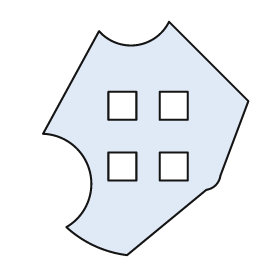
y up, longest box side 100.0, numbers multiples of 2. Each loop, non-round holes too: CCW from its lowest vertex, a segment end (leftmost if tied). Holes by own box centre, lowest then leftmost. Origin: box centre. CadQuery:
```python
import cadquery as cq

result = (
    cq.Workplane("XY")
    .moveTo(-8.0, -50.0)
    .lineTo(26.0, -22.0)
    .threePointArc((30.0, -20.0), (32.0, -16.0))
    .lineTo(44.0, 16.0)
    .lineTo(10.0, 50.0)
    .threePointArc((-4.0, 40.0), (-20.0, 46.0))
    .lineTo(-44.0, 2.0)
    .threePointArc((-24.0, -14.0), (-34.0, -38.0))
    .threePointArc((-22.0, -46.0), (-8.0, -50.0))
    .close()
    .moveTo(-16.0, -18.0)
    .lineTo(-4.0, -18.0)
    .lineTo(-4.0, -6.0)
    .lineTo(-16.0, -6.0)
    .close()
    .moveTo(6.0, -18.0)
    .lineTo(18.0, -18.0)
    .lineTo(18.0, -6.0)
    .lineTo(6.0, -6.0)
    .close()
    .moveTo(-16.0, 8.0)
    .lineTo(-4.0, 8.0)
    .lineTo(-4.0, 20.0)
    .lineTo(-16.0, 20.0)
    .close()
    .moveTo(6.0, 8.0)
    .lineTo(18.0, 8.0)
    .lineTo(18.0, 20.0)
    .lineTo(6.0, 20.0)
    .close()
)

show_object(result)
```